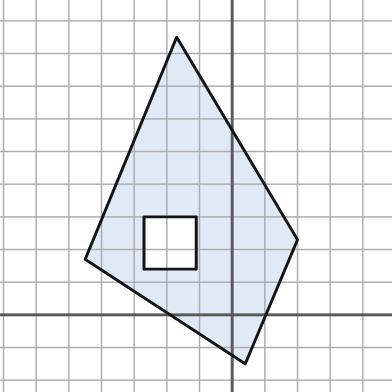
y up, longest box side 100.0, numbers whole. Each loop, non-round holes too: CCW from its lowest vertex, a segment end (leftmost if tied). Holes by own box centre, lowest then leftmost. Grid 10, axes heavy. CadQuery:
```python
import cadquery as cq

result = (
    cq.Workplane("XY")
    .moveTo(4.0, -15.0)
    .lineTo(20.0, 23.0)
    .lineTo(-17.0, 85.0)
    .lineTo(-45.0, 17.0)
    .close()
    .moveTo(-27.0, 14.0)
    .lineTo(-11.0, 14.0)
    .lineTo(-11.0, 30.0)
    .lineTo(-27.0, 30.0)
    .close()
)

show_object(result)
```